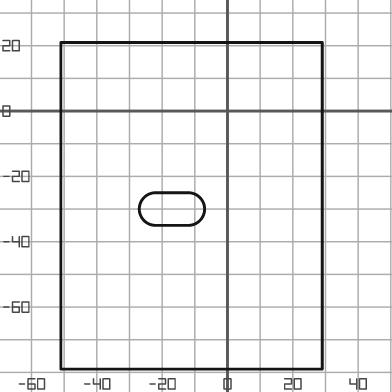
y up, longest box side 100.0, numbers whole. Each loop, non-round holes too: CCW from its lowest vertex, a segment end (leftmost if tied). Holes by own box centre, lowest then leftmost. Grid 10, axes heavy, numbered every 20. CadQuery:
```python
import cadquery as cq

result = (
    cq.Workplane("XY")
    .moveTo(-51.0, -79.0)
    .lineTo(29.0, -79.0)
    .lineTo(29.0, 21.0)
    .lineTo(-51.0, 21.0)
    .close()
    .moveTo(-22.0, -35.0)
    .lineTo(-12.0, -35.0)
    .threePointArc((-7.0, -30.0), (-12.0, -25.0))
    .lineTo(-22.0, -25.0)
    .threePointArc((-27.0, -30.0), (-22.0, -35.0))
    .close()
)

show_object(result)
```